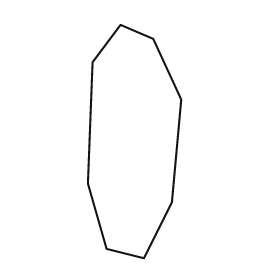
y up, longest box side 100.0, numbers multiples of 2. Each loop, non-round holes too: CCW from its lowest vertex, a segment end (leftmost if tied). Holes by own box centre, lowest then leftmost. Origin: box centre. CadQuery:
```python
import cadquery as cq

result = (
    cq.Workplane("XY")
    .moveTo(4.0, -50.0)
    .lineTo(16.0, -26.0)
    .lineTo(20.0, 18.0)
    .lineTo(8.0, 44.0)
    .lineTo(-6.0, 50.0)
    .lineTo(-18.0, 34.0)
    .lineTo(-20.0, -18.0)
    .lineTo(-12.0, -46.0)
    .close()
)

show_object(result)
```